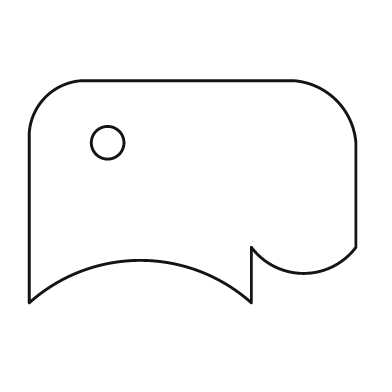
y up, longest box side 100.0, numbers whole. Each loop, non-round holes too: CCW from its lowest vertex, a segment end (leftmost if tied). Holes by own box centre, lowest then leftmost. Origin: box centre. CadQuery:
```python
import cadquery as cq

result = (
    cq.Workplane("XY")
    .moveTo(-50.0, -34.0)
    .threePointArc((-16.0, -21.0), (18.0, -34.0))
    .lineTo(18.0, -17.0)
    .threePointArc((34.0, -25.0), (50.0, -17.0))
    .lineTo(50.0, 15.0)
    .threePointArc((44.0, 28.0), (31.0, 34.0))
    .lineTo(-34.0, 34.0)
    .threePointArc((-45.0, 29.0), (-50.0, 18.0))
    .close()
    .moveTo(-26.0, 15.0)
    .circle(5.0)
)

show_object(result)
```